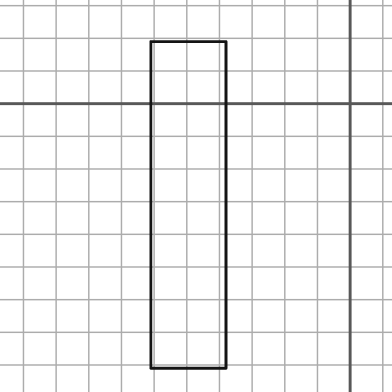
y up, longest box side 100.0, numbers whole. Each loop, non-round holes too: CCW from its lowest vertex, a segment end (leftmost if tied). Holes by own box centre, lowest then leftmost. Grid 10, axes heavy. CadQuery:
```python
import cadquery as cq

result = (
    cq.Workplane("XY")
    .moveTo(-61.0, -81.0)
    .lineTo(-38.0, -81.0)
    .lineTo(-38.0, 19.0)
    .lineTo(-61.0, 19.0)
    .close()
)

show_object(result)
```